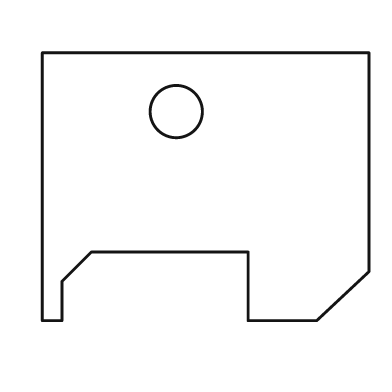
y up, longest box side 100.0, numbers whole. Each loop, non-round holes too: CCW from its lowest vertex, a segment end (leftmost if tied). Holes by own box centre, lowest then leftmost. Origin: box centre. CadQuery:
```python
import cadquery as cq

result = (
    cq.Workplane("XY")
    .moveTo(-50.0, -41.0)
    .lineTo(-44.0, -41.0)
    .lineTo(-44.0, -29.0)
    .lineTo(-35.0, -20.0)
    .lineTo(13.0, -20.0)
    .lineTo(13.0, -41.0)
    .lineTo(34.0, -41.0)
    .lineTo(50.0, -26.0)
    .lineTo(50.0, 41.0)
    .lineTo(-50.0, 41.0)
    .close()
    .moveTo(-9.0, 23.0)
    .circle(8.0)
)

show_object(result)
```